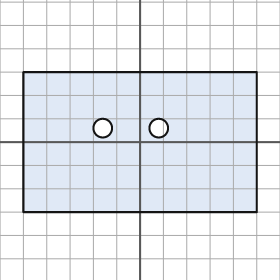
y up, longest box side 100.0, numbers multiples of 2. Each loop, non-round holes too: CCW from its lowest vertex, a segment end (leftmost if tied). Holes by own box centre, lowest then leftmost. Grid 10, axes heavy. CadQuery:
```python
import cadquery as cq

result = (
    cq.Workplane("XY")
    .moveTo(-50.0, -30.0)
    .lineTo(50.0, -30.0)
    .lineTo(50.0, 30.0)
    .lineTo(-50.0, 30.0)
    .close()
    .moveTo(-16.0, 6.0)
    .circle(4.0)
    .moveTo(8.0, 6.0)
    .circle(4.0)
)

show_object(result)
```